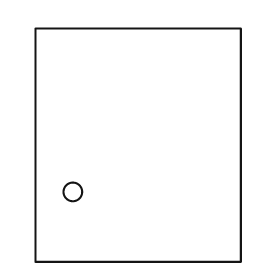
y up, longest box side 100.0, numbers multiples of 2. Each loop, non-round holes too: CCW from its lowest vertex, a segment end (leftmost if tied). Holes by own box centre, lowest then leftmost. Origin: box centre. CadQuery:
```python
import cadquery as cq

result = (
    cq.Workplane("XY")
    .moveTo(-44.0, -50.0)
    .lineTo(44.0, -50.0)
    .lineTo(44.0, 50.0)
    .lineTo(-44.0, 50.0)
    .close()
    .moveTo(-28.0, -20.0)
    .circle(4.0)
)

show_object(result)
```